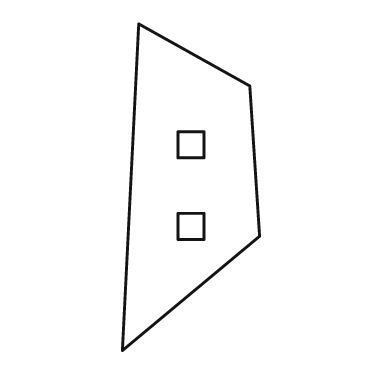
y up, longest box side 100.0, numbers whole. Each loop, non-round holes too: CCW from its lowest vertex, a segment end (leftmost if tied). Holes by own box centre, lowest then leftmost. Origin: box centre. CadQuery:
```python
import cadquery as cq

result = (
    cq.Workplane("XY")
    .moveTo(-21.0, -50.0)
    .lineTo(21.0, -15.0)
    .lineTo(18.0, 31.0)
    .lineTo(-16.0, 50.0)
    .close()
    .moveTo(-4.0, -16.0)
    .lineTo(4.0, -16.0)
    .lineTo(4.0, -8.0)
    .lineTo(-4.0, -8.0)
    .close()
    .moveTo(-4.0, 9.0)
    .lineTo(4.0, 9.0)
    .lineTo(4.0, 17.0)
    .lineTo(-4.0, 17.0)
    .close()
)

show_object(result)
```